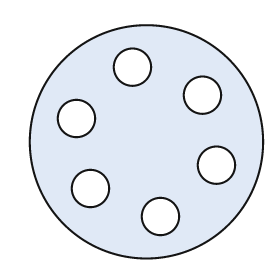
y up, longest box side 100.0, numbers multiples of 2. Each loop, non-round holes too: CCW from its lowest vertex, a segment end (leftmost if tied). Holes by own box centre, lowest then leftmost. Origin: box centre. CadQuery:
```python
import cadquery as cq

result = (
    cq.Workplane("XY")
    .moveTo(0.0, 0.0)
    .circle(50.0)
    .moveTo(6.0, -32.0)
    .circle(8.0)
    .moveTo(-24.0, -20.0)
    .circle(8.0)
    .moveTo(30.0, -10.0)
    .circle(8.0)
    .moveTo(-30.0, 10.0)
    .circle(8.0)
    .moveTo(24.0, 20.0)
    .circle(8.0)
    .moveTo(-6.0, 32.0)
    .circle(8.0)
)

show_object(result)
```